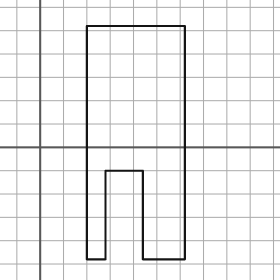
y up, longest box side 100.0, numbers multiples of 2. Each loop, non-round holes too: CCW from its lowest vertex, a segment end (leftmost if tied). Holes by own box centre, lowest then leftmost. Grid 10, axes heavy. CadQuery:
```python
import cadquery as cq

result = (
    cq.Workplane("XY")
    .moveTo(20.0, -48.0)
    .lineTo(28.0, -48.0)
    .lineTo(28.0, -10.0)
    .lineTo(44.0, -10.0)
    .lineTo(44.0, -48.0)
    .lineTo(62.0, -48.0)
    .lineTo(62.0, 52.0)
    .lineTo(20.0, 52.0)
    .close()
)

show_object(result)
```